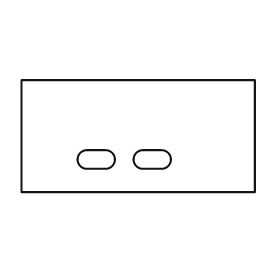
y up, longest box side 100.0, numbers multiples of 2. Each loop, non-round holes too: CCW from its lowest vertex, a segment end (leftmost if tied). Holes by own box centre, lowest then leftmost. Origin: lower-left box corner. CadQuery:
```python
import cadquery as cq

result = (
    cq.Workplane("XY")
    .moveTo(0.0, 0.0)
    .lineTo(100.0, 0.0)
    .lineTo(100.0, 48.0)
    .lineTo(0.0, 48.0)
    .close()
    .moveTo(28.0, 10.0)
    .lineTo(36.0, 10.0)
    .threePointArc((40.0, 14.0), (36.0, 18.0))
    .lineTo(28.0, 18.0)
    .threePointArc((24.0, 14.0), (28.0, 10.0))
    .close()
    .moveTo(52.0, 10.0)
    .lineTo(60.0, 10.0)
    .threePointArc((64.0, 14.0), (60.0, 18.0))
    .lineTo(52.0, 18.0)
    .threePointArc((48.0, 14.0), (52.0, 10.0))
    .close()
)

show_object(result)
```